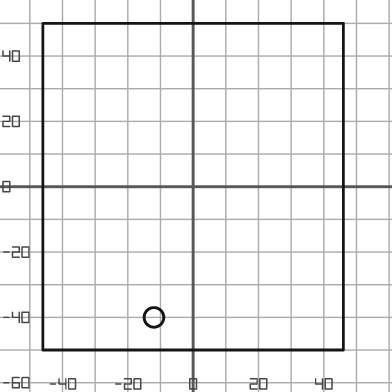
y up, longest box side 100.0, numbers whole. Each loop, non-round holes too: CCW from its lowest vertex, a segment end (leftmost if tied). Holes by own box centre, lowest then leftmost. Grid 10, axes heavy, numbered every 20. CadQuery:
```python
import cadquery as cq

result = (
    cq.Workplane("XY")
    .moveTo(-46.0, -50.0)
    .lineTo(46.0, -50.0)
    .lineTo(46.0, 50.0)
    .lineTo(-46.0, 50.0)
    .close()
    .moveTo(-12.0, -40.0)
    .circle(3.0)
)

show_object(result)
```